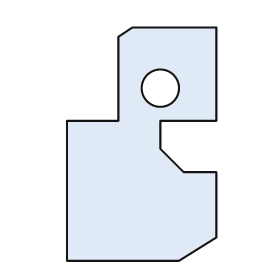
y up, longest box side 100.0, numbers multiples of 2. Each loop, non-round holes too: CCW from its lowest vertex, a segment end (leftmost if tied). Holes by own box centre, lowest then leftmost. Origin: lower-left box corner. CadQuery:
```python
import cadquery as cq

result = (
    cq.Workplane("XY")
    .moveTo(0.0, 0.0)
    .lineTo(48.0, 0.0)
    .lineTo(64.0, 10.0)
    .lineTo(64.0, 38.0)
    .lineTo(50.0, 38.0)
    .lineTo(40.0, 48.0)
    .lineTo(40.0, 60.0)
    .lineTo(64.0, 60.0)
    .lineTo(64.0, 100.0)
    .lineTo(28.0, 100.0)
    .lineTo(22.0, 96.0)
    .lineTo(22.0, 60.0)
    .lineTo(0.0, 60.0)
    .close()
    .moveTo(40.0, 74.0)
    .circle(8.0)
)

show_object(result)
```